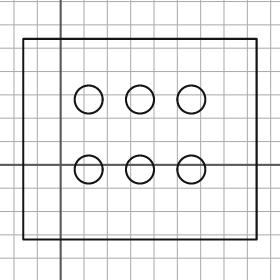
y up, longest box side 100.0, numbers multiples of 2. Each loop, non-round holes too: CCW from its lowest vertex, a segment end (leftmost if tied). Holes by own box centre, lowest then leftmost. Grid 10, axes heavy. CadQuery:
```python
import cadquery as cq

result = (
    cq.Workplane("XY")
    .moveTo(-16.0, -32.0)
    .lineTo(84.0, -32.0)
    .lineTo(84.0, 54.0)
    .lineTo(-16.0, 54.0)
    .close()
    .moveTo(12.0, -2.0)
    .circle(6.0)
    .moveTo(34.0, -2.0)
    .circle(6.0)
    .moveTo(56.0, -2.0)
    .circle(6.0)
    .moveTo(12.0, 28.0)
    .circle(6.0)
    .moveTo(34.0, 28.0)
    .circle(6.0)
    .moveTo(56.0, 28.0)
    .circle(6.0)
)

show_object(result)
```